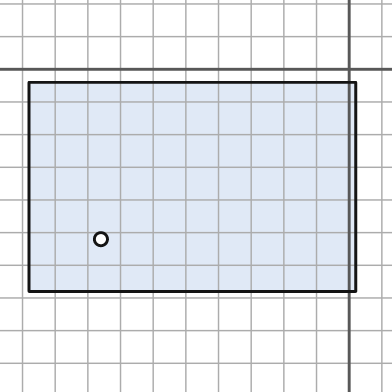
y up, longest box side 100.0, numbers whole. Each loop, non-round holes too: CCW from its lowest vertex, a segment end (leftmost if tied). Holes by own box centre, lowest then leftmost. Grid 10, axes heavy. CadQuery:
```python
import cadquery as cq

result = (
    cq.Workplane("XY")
    .moveTo(-98.0, -68.0)
    .lineTo(2.0, -68.0)
    .lineTo(2.0, -4.0)
    .lineTo(-98.0, -4.0)
    .close()
    .moveTo(-76.0, -52.0)
    .circle(2.0)
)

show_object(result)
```